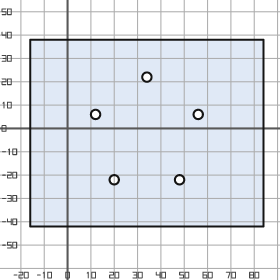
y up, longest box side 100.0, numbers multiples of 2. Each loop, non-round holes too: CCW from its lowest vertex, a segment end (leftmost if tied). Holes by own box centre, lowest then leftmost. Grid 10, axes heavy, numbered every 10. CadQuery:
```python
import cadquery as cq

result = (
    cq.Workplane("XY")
    .moveTo(-16.0, -42.0)
    .lineTo(84.0, -42.0)
    .lineTo(84.0, 38.0)
    .lineTo(-16.0, 38.0)
    .close()
    .moveTo(20.0, -22.0)
    .circle(2.0)
    .moveTo(48.0, -22.0)
    .circle(2.0)
    .moveTo(12.0, 6.0)
    .circle(2.0)
    .moveTo(56.0, 6.0)
    .circle(2.0)
    .moveTo(34.0, 22.0)
    .circle(2.0)
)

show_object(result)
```